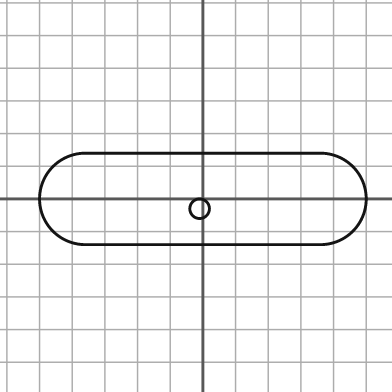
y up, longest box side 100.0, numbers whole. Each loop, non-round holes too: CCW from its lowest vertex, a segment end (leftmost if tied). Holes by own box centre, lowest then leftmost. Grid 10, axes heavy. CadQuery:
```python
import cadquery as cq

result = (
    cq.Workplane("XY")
    .moveTo(-36.0, -14.0)
    .lineTo(36.0, -14.0)
    .threePointArc((50.0, 0.0), (36.0, 14.0))
    .lineTo(-36.0, 14.0)
    .threePointArc((-50.0, 0.0), (-36.0, -14.0))
    .close()
    .moveTo(-1.0, -3.0)
    .circle(3.0)
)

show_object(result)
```